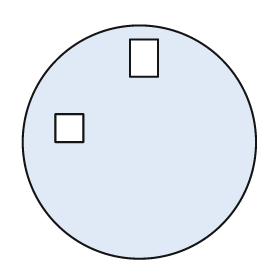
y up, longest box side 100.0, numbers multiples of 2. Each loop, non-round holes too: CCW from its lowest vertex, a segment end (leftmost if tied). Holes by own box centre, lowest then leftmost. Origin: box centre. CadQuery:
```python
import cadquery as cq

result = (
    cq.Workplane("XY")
    .moveTo(0.0, 0.0)
    .circle(50.0)
    .moveTo(-36.0, 0.0)
    .lineTo(-24.0, 0.0)
    .lineTo(-24.0, 12.0)
    .lineTo(-36.0, 12.0)
    .close()
    .moveTo(-4.0, 28.0)
    .lineTo(8.0, 28.0)
    .lineTo(8.0, 44.0)
    .lineTo(-4.0, 44.0)
    .close()
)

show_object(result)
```